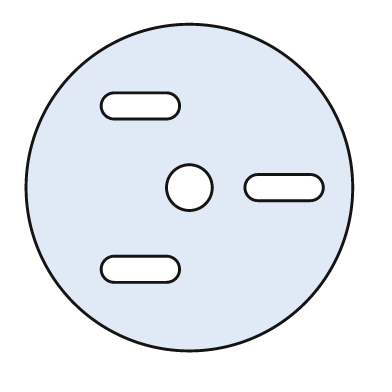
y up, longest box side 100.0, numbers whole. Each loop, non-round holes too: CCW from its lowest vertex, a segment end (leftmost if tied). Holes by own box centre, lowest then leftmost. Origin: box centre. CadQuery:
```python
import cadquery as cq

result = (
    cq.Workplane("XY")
    .moveTo(0.0, 0.0)
    .circle(50.0)
    .moveTo(-23.0, -29.0)
    .lineTo(-7.0, -29.0)
    .threePointArc((-3.0, -25.0), (-7.0, -21.0))
    .lineTo(-23.0, -21.0)
    .threePointArc((-27.0, -25.0), (-23.0, -29.0))
    .close()
    .moveTo(0.0, 0.0)
    .circle(7.0)
    .moveTo(21.0, -4.0)
    .lineTo(37.0, -4.0)
    .threePointArc((41.0, 0.0), (37.0, 4.0))
    .lineTo(21.0, 4.0)
    .threePointArc((17.0, 0.0), (21.0, -4.0))
    .close()
    .moveTo(-23.0, 21.0)
    .lineTo(-7.0, 21.0)
    .threePointArc((-3.0, 25.0), (-7.0, 29.0))
    .lineTo(-23.0, 29.0)
    .threePointArc((-27.0, 25.0), (-23.0, 21.0))
    .close()
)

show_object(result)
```